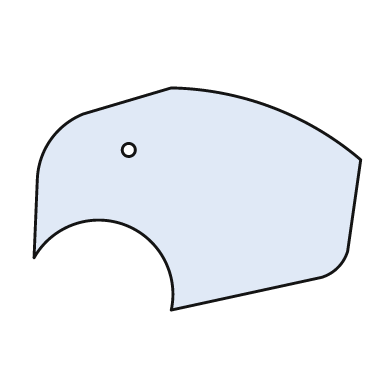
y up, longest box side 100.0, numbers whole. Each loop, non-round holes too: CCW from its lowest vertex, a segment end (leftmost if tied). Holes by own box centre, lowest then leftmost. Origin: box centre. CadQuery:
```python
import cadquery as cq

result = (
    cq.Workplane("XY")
    .moveTo(-8.0, -34.0)
    .lineTo(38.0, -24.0)
    .threePointArc((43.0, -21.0), (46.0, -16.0))
    .lineTo(50.0, 12.0)
    .threePointArc((23.0, 28.0), (-8.0, 34.0))
    .lineTo(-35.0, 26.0)
    .threePointArc((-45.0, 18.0), (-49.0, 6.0))
    .lineTo(-50.0, -18.0)
    .threePointArc((-22.0, -8.0), (-8.0, -34.0))
    .close()
    .moveTo(-21.0, 15.0)
    .circle(2.0)
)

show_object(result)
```